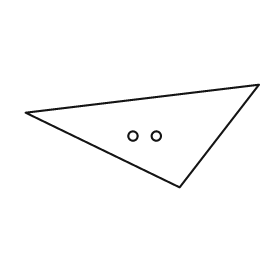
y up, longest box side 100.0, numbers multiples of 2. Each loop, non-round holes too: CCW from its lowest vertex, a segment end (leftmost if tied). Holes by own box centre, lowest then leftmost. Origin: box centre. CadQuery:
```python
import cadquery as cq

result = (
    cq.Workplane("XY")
    .moveTo(16.0, -22.0)
    .lineTo(50.0, 22.0)
    .lineTo(-50.0, 10.0)
    .close()
    .moveTo(-4.0, 0.0)
    .circle(2.0)
    .moveTo(6.0, 0.0)
    .circle(2.0)
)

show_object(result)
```